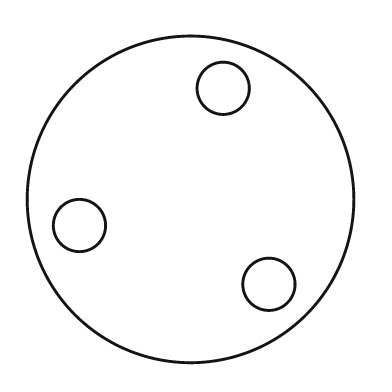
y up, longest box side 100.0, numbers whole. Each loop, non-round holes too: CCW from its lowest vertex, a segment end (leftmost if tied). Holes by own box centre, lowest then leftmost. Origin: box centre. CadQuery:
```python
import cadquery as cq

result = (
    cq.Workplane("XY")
    .moveTo(0.0, 0.0)
    .circle(50.0)
    .moveTo(24.0, -26.0)
    .circle(8.0)
    .moveTo(-34.0, -8.0)
    .circle(8.0)
    .moveTo(10.0, 34.0)
    .circle(8.0)
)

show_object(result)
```